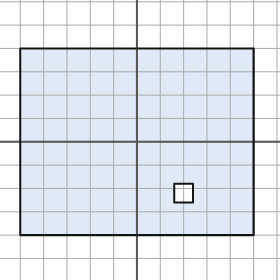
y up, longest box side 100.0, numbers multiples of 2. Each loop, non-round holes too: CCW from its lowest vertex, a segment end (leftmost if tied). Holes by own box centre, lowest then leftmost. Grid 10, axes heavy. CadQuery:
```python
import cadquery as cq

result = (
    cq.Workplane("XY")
    .moveTo(-50.0, -40.0)
    .lineTo(50.0, -40.0)
    .lineTo(50.0, 40.0)
    .lineTo(-50.0, 40.0)
    .close()
    .moveTo(16.0, -26.0)
    .lineTo(24.0, -26.0)
    .lineTo(24.0, -18.0)
    .lineTo(16.0, -18.0)
    .close()
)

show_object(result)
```